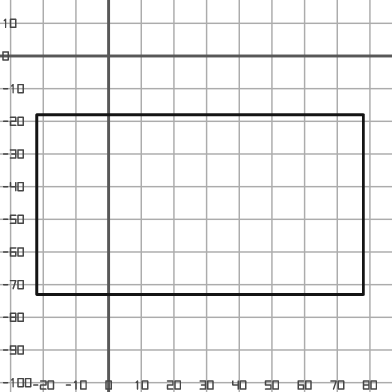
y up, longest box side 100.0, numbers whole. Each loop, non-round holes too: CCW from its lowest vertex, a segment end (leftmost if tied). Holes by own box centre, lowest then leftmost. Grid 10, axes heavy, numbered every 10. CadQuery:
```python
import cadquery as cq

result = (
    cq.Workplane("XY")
    .moveTo(-22.0, -73.0)
    .lineTo(78.0, -73.0)
    .lineTo(78.0, -18.0)
    .lineTo(-22.0, -18.0)
    .close()
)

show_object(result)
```